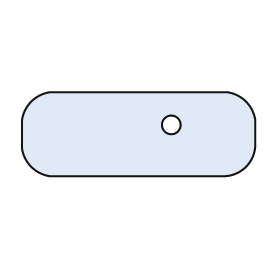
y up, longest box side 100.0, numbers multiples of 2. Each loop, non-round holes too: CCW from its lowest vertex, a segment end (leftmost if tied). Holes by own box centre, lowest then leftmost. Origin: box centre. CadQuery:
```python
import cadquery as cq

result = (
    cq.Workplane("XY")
    .moveTo(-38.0, -18.0)
    .lineTo(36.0, -18.0)
    .threePointArc((46.0, -14.0), (50.0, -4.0))
    .lineTo(50.0, 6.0)
    .threePointArc((46.0, 14.0), (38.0, 18.0))
    .lineTo(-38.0, 18.0)
    .threePointArc((-46.0, 14.0), (-50.0, 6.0))
    .lineTo(-50.0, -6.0)
    .threePointArc((-46.0, -14.0), (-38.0, -18.0))
    .close()
    .moveTo(14.0, 4.0)
    .circle(4.0)
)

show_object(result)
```